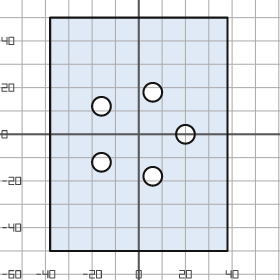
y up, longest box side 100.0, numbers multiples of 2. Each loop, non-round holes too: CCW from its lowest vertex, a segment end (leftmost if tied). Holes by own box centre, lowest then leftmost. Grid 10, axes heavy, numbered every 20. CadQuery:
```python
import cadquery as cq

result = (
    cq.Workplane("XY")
    .moveTo(-38.0, -50.0)
    .lineTo(38.0, -50.0)
    .lineTo(38.0, 50.0)
    .lineTo(-38.0, 50.0)
    .close()
    .moveTo(6.0, -18.0)
    .circle(4.0)
    .moveTo(-16.0, -12.0)
    .circle(4.0)
    .moveTo(20.0, 0.0)
    .circle(4.0)
    .moveTo(-16.0, 12.0)
    .circle(4.0)
    .moveTo(6.0, 18.0)
    .circle(4.0)
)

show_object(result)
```